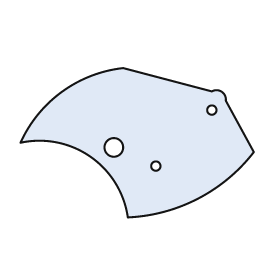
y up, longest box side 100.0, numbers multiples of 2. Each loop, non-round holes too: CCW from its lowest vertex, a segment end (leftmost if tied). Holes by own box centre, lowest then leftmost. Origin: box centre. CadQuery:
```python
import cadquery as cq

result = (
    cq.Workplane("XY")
    .moveTo(-4.0, -32.0)
    .threePointArc((26.0, -24.0), (50.0, -4.0))
    .lineTo(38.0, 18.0)
    .threePointArc((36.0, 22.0), (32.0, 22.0))
    .lineTo(-6.0, 32.0)
    .threePointArc((-32.0, 22.0), (-50.0, 0.0))
    .threePointArc((-20.0, -6.0), (-4.0, -32.0))
    .close()
    .moveTo(8.0, -10.0)
    .circle(2.0)
    .moveTo(-10.0, -2.0)
    .circle(4.0)
    .moveTo(32.0, 14.0)
    .circle(2.0)
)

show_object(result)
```